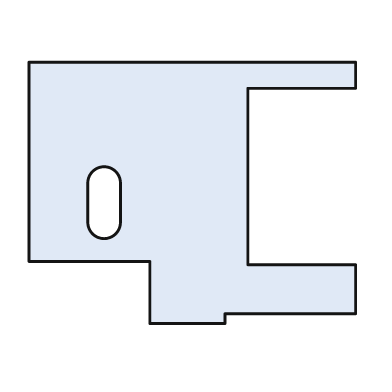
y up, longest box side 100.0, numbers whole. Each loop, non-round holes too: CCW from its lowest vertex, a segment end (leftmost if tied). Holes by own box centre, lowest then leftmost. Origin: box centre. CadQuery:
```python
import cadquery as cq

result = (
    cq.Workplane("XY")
    .moveTo(-13.0, -40.0)
    .lineTo(10.0, -40.0)
    .lineTo(10.0, -37.0)
    .lineTo(50.0, -37.0)
    .lineTo(50.0, -22.0)
    .lineTo(17.0, -22.0)
    .lineTo(17.0, 32.0)
    .lineTo(50.0, 32.0)
    .lineTo(50.0, 40.0)
    .lineTo(-50.0, 40.0)
    .lineTo(-50.0, -21.0)
    .lineTo(-13.0, -21.0)
    .close()
    .moveTo(-32.0, -9.0)
    .threePointArc((-27.0, -14.0), (-22.0, -9.0))
    .lineTo(-22.0, 3.0)
    .threePointArc((-27.0, 8.0), (-32.0, 3.0))
    .close()
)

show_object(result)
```